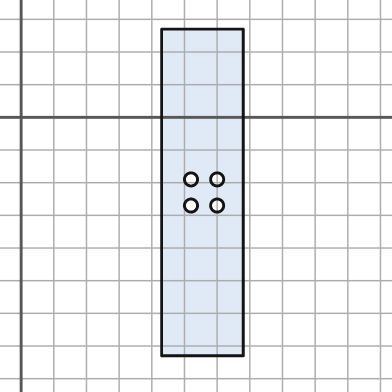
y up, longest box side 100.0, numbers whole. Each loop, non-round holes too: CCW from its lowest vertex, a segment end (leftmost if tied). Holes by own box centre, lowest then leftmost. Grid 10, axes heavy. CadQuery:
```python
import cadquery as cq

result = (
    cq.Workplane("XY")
    .moveTo(43.0, -73.0)
    .lineTo(68.0, -73.0)
    .lineTo(68.0, 27.0)
    .lineTo(43.0, 27.0)
    .close()
    .moveTo(52.0, -27.0)
    .circle(2.0)
    .moveTo(60.0, -27.0)
    .circle(2.0)
    .moveTo(52.0, -19.0)
    .circle(2.0)
    .moveTo(60.0, -19.0)
    .circle(2.0)
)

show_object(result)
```